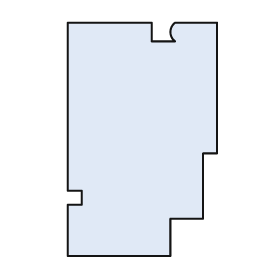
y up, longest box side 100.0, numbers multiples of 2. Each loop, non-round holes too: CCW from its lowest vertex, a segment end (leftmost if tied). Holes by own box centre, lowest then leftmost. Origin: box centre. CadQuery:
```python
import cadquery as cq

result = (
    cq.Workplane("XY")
    .moveTo(-32.0, -50.0)
    .lineTo(12.0, -50.0)
    .lineTo(12.0, -34.0)
    .lineTo(26.0, -34.0)
    .lineTo(26.0, -6.0)
    .lineTo(32.0, -6.0)
    .lineTo(32.0, 50.0)
    .lineTo(14.0, 50.0)
    .threePointArc((12.0, 46.0), (14.0, 42.0))
    .lineTo(4.0, 42.0)
    .lineTo(4.0, 50.0)
    .lineTo(-32.0, 50.0)
    .lineTo(-32.0, -22.0)
    .lineTo(-26.0, -22.0)
    .lineTo(-26.0, -28.0)
    .lineTo(-32.0, -28.0)
    .close()
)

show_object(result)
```